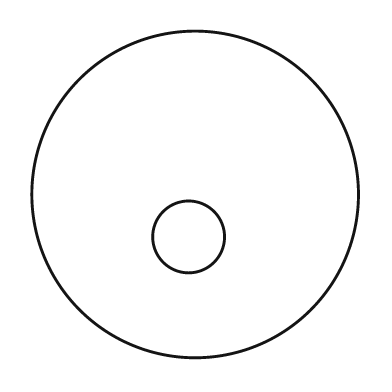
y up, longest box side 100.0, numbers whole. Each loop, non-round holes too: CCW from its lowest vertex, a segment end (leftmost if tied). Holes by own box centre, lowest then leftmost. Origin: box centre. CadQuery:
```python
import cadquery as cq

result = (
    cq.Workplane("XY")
    .moveTo(0.0, 0.0)
    .circle(50.0)
    .moveTo(-2.0, -13.0)
    .circle(11.0)
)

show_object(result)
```